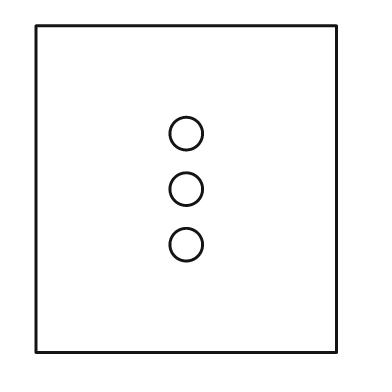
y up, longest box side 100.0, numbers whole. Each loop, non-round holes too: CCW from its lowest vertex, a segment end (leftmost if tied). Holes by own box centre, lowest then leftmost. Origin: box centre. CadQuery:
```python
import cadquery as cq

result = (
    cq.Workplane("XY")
    .moveTo(-46.0, -50.0)
    .lineTo(46.0, -50.0)
    .lineTo(46.0, 50.0)
    .lineTo(-46.0, 50.0)
    .close()
    .moveTo(0.0, -17.0)
    .circle(5.0)
    .moveTo(0.0, 0.0)
    .circle(5.0)
    .moveTo(0.0, 17.0)
    .circle(5.0)
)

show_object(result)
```